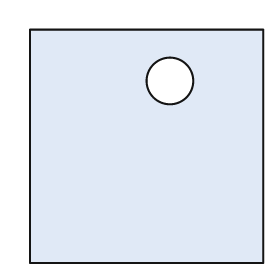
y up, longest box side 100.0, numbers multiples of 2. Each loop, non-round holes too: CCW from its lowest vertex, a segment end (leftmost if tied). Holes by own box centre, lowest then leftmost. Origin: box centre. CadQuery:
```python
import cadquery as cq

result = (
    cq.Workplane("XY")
    .moveTo(-50.0, -50.0)
    .lineTo(50.0, -50.0)
    .lineTo(50.0, 50.0)
    .lineTo(-50.0, 50.0)
    .close()
    .moveTo(10.0, 28.0)
    .circle(10.0)
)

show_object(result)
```